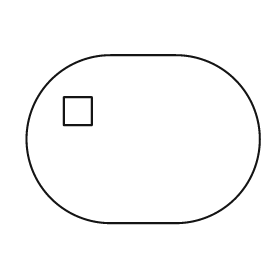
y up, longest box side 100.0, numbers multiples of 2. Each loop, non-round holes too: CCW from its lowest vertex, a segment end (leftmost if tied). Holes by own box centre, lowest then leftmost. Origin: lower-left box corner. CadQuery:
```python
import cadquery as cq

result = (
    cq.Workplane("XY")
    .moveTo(36.0, 0.0)
    .lineTo(64.0, 0.0)
    .threePointArc((100.0, 36.0), (64.0, 72.0))
    .lineTo(36.0, 72.0)
    .threePointArc((0.0, 36.0), (36.0, 0.0))
    .close()
    .moveTo(16.0, 42.0)
    .lineTo(28.0, 42.0)
    .lineTo(28.0, 54.0)
    .lineTo(16.0, 54.0)
    .close()
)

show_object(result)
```